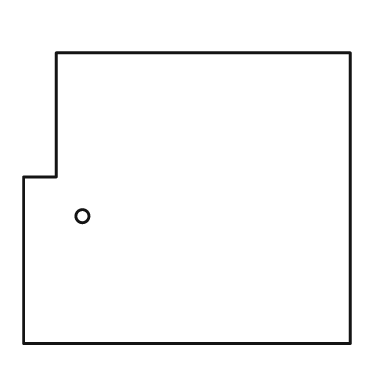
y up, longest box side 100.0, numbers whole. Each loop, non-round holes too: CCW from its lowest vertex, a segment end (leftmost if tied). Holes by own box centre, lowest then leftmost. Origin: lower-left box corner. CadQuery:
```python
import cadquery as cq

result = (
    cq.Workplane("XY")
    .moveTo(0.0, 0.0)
    .lineTo(100.0, 0.0)
    .lineTo(100.0, 89.0)
    .lineTo(10.0, 89.0)
    .lineTo(10.0, 51.0)
    .lineTo(0.0, 51.0)
    .close()
    .moveTo(18.0, 39.0)
    .circle(2.0)
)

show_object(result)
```